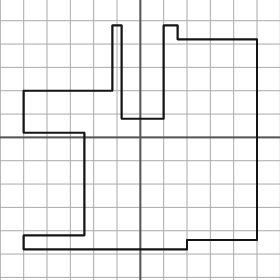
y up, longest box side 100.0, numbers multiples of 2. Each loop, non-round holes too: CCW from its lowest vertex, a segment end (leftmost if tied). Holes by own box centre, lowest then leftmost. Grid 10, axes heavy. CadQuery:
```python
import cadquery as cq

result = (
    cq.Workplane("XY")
    .moveTo(-50.0, -48.0)
    .lineTo(20.0, -48.0)
    .lineTo(20.0, -44.0)
    .lineTo(50.0, -44.0)
    .lineTo(50.0, 42.0)
    .lineTo(16.0, 42.0)
    .lineTo(16.0, 48.0)
    .lineTo(10.0, 48.0)
    .lineTo(10.0, 8.0)
    .lineTo(-8.0, 8.0)
    .lineTo(-8.0, 48.0)
    .lineTo(-12.0, 48.0)
    .lineTo(-12.0, 20.0)
    .lineTo(-50.0, 20.0)
    .lineTo(-50.0, 2.0)
    .lineTo(-24.0, 2.0)
    .lineTo(-24.0, -42.0)
    .lineTo(-50.0, -42.0)
    .close()
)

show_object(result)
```